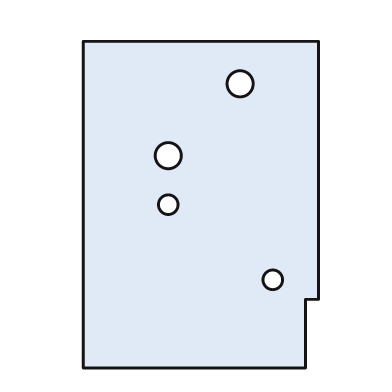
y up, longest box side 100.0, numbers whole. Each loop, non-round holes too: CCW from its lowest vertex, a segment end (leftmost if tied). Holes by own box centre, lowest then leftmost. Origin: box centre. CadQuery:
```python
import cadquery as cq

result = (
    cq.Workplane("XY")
    .moveTo(-36.0, -50.0)
    .lineTo(32.0, -50.0)
    .lineTo(32.0, -29.0)
    .lineTo(36.0, -29.0)
    .lineTo(36.0, 50.0)
    .lineTo(-36.0, 50.0)
    .close()
    .moveTo(22.0, -23.0)
    .circle(3.0)
    .moveTo(-10.0, 0.0)
    .circle(3.0)
    .moveTo(-10.0, 15.0)
    .circle(4.0)
    .moveTo(12.0, 37.0)
    .circle(4.0)
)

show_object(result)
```